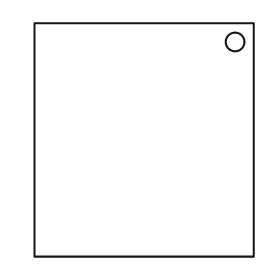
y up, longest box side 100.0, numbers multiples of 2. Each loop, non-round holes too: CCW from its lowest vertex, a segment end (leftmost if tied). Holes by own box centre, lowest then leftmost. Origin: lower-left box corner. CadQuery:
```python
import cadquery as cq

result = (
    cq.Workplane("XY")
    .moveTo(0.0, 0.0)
    .lineTo(94.0, 0.0)
    .lineTo(94.0, 100.0)
    .lineTo(0.0, 100.0)
    .close()
    .moveTo(86.0, 92.0)
    .circle(4.0)
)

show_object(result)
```